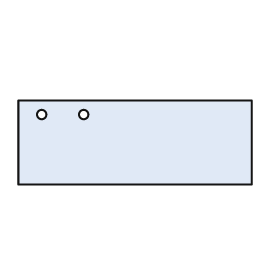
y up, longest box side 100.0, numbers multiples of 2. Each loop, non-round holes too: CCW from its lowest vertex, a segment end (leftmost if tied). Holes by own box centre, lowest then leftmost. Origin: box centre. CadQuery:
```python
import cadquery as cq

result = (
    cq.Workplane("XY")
    .moveTo(-50.0, -18.0)
    .lineTo(50.0, -18.0)
    .lineTo(50.0, 18.0)
    .lineTo(-50.0, 18.0)
    .close()
    .moveTo(-40.0, 12.0)
    .circle(2.0)
    .moveTo(-22.0, 12.0)
    .circle(2.0)
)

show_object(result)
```